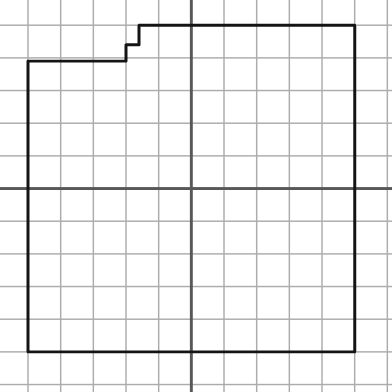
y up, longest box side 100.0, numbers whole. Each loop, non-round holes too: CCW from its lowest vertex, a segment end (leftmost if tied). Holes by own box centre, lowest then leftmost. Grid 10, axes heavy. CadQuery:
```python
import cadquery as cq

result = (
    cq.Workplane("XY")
    .moveTo(-50.0, -50.0)
    .lineTo(50.0, -50.0)
    .lineTo(50.0, 50.0)
    .lineTo(-16.0, 50.0)
    .lineTo(-16.0, 44.0)
    .lineTo(-20.0, 44.0)
    .lineTo(-20.0, 39.0)
    .lineTo(-50.0, 39.0)
    .close()
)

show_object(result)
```